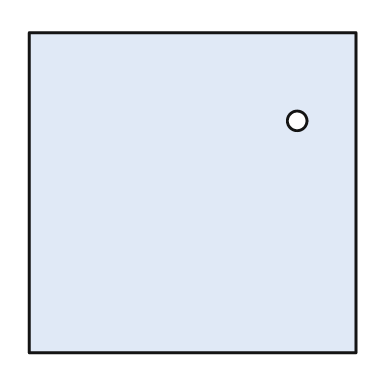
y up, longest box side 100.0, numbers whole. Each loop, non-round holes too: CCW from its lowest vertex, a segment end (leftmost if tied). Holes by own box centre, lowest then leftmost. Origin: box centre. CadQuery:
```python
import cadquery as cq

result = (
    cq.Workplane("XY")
    .moveTo(-50.0, -49.0)
    .lineTo(50.0, -49.0)
    .lineTo(50.0, 49.0)
    .lineTo(-50.0, 49.0)
    .close()
    .moveTo(32.0, 22.0)
    .circle(3.0)
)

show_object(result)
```